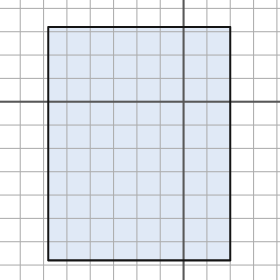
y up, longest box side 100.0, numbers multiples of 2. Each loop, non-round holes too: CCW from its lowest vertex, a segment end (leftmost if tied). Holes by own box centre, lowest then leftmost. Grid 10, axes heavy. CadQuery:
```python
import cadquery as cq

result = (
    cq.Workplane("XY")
    .moveTo(-58.0, -68.0)
    .lineTo(20.0, -68.0)
    .lineTo(20.0, 32.0)
    .lineTo(-58.0, 32.0)
    .close()
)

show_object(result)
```